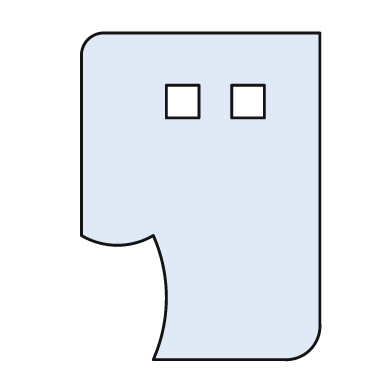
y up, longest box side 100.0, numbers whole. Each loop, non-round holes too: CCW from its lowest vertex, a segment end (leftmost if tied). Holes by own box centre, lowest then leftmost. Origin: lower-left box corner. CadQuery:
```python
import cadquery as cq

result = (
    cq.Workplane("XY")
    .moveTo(22.0, 0.0)
    .lineTo(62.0, 0.0)
    .threePointArc((70.0, 3.0), (73.0, 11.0))
    .lineTo(73.0, 100.0)
    .lineTo(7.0, 100.0)
    .threePointArc((2.0, 98.0), (0.0, 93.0))
    .lineTo(0.0, 38.0)
    .threePointArc((11.0, 35.0), (22.0, 38.0))
    .threePointArc((26.0, 19.0), (22.0, 0.0))
    .close()
    .moveTo(26.0, 74.0)
    .lineTo(36.0, 74.0)
    .lineTo(36.0, 84.0)
    .lineTo(26.0, 84.0)
    .close()
    .moveTo(46.0, 74.0)
    .lineTo(56.0, 74.0)
    .lineTo(56.0, 84.0)
    .lineTo(46.0, 84.0)
    .close()
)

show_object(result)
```